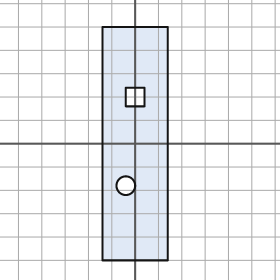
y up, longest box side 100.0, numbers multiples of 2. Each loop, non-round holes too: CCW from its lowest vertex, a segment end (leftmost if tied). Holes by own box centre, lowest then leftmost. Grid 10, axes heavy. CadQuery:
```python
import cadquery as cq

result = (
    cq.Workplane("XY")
    .moveTo(-14.0, -50.0)
    .lineTo(14.0, -50.0)
    .lineTo(14.0, 50.0)
    .lineTo(-14.0, 50.0)
    .close()
    .moveTo(-4.0, -18.0)
    .circle(4.0)
    .moveTo(-4.0, 16.0)
    .lineTo(4.0, 16.0)
    .lineTo(4.0, 24.0)
    .lineTo(-4.0, 24.0)
    .close()
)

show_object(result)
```